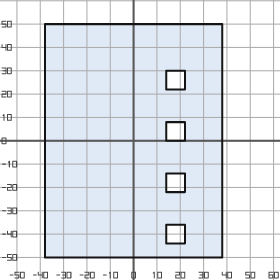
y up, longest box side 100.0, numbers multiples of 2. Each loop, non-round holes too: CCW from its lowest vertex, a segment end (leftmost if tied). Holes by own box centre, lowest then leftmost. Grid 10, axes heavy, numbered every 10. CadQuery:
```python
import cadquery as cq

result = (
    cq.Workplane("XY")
    .moveTo(-38.0, -50.0)
    .lineTo(38.0, -50.0)
    .lineTo(38.0, 50.0)
    .lineTo(-38.0, 50.0)
    .close()
    .moveTo(14.0, -44.0)
    .lineTo(22.0, -44.0)
    .lineTo(22.0, -36.0)
    .lineTo(14.0, -36.0)
    .close()
    .moveTo(14.0, -22.0)
    .lineTo(22.0, -22.0)
    .lineTo(22.0, -14.0)
    .lineTo(14.0, -14.0)
    .close()
    .moveTo(14.0, 0.0)
    .lineTo(22.0, 0.0)
    .lineTo(22.0, 8.0)
    .lineTo(14.0, 8.0)
    .close()
    .moveTo(14.0, 22.0)
    .lineTo(22.0, 22.0)
    .lineTo(22.0, 30.0)
    .lineTo(14.0, 30.0)
    .close()
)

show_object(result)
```